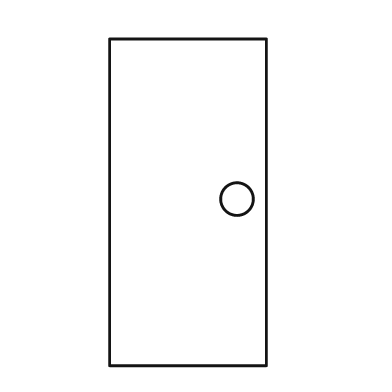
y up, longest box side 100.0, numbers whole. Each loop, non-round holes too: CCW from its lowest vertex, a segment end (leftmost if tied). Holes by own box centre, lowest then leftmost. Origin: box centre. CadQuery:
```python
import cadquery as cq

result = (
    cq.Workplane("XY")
    .moveTo(-24.0, -50.0)
    .lineTo(24.0, -50.0)
    .lineTo(24.0, 50.0)
    .lineTo(-24.0, 50.0)
    .close()
    .moveTo(15.0, 1.0)
    .circle(5.0)
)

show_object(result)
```